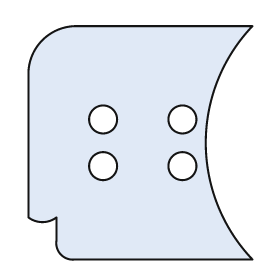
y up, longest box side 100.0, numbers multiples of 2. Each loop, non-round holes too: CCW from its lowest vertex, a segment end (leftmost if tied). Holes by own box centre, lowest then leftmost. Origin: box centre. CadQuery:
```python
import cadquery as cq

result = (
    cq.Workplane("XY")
    .moveTo(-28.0, -50.0)
    .lineTo(48.0, -50.0)
    .threePointArc((28.0, 0.0), (48.0, 50.0))
    .lineTo(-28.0, 50.0)
    .threePointArc((-42.0, 44.0), (-48.0, 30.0))
    .lineTo(-48.0, -32.0)
    .threePointArc((-42.0, -34.0), (-36.0, -32.0))
    .lineTo(-36.0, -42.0)
    .threePointArc((-34.0, -48.0), (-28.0, -50.0))
    .close()
    .moveTo(-16.0, -10.0)
    .circle(6.0)
    .moveTo(18.0, -10.0)
    .circle(6.0)
    .moveTo(-16.0, 10.0)
    .circle(6.0)
    .moveTo(18.0, 10.0)
    .circle(6.0)
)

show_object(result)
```